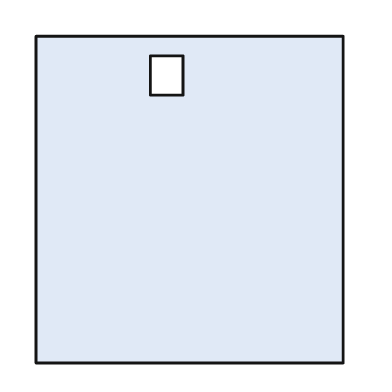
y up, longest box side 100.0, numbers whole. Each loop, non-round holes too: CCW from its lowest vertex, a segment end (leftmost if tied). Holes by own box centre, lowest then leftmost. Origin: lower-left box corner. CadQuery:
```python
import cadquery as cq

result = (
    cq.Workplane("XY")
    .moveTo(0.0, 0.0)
    .lineTo(94.0, 0.0)
    .lineTo(94.0, 100.0)
    .lineTo(0.0, 100.0)
    .close()
    .moveTo(35.0, 82.0)
    .lineTo(45.0, 82.0)
    .lineTo(45.0, 94.0)
    .lineTo(35.0, 94.0)
    .close()
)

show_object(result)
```